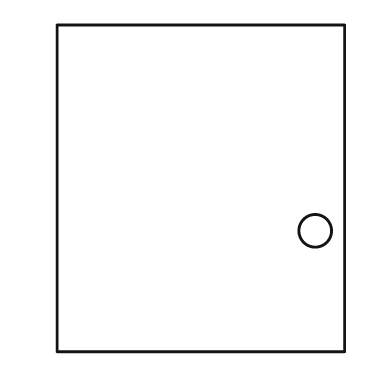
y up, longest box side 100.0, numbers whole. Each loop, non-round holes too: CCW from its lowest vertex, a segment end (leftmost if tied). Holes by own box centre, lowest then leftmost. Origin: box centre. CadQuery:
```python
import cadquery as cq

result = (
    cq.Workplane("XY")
    .moveTo(-44.0, -50.0)
    .lineTo(44.0, -50.0)
    .lineTo(44.0, 50.0)
    .lineTo(-44.0, 50.0)
    .close()
    .moveTo(35.0, -13.0)
    .circle(5.0)
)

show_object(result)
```